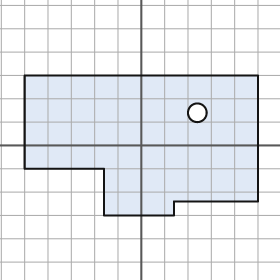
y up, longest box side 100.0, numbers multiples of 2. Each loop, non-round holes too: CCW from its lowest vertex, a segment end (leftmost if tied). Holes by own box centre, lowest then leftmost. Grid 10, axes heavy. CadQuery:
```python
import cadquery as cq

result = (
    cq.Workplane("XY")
    .moveTo(-16.0, -30.0)
    .lineTo(14.0, -30.0)
    .lineTo(14.0, -24.0)
    .lineTo(50.0, -24.0)
    .lineTo(50.0, 30.0)
    .lineTo(-50.0, 30.0)
    .lineTo(-50.0, -10.0)
    .lineTo(-16.0, -10.0)
    .close()
    .moveTo(24.0, 14.0)
    .circle(4.0)
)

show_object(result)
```